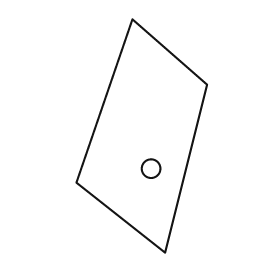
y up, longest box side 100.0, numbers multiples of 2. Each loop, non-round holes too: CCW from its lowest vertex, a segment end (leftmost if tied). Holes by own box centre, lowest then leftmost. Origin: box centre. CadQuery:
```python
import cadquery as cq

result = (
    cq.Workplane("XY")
    .moveTo(10.0, -50.0)
    .lineTo(28.0, 22.0)
    .lineTo(-4.0, 50.0)
    .lineTo(-28.0, -20.0)
    .close()
    .moveTo(4.0, -14.0)
    .circle(4.0)
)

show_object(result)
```